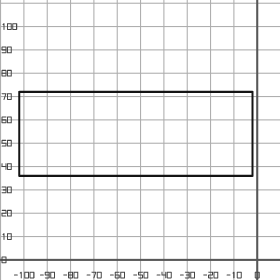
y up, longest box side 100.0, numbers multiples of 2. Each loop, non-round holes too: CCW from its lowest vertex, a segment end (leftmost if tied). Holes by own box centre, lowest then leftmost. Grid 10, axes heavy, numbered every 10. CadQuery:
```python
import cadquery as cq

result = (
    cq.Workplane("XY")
    .moveTo(-102.0, 36.0)
    .lineTo(-2.0, 36.0)
    .lineTo(-2.0, 72.0)
    .lineTo(-102.0, 72.0)
    .close()
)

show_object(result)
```